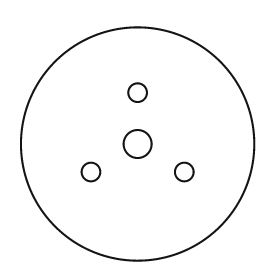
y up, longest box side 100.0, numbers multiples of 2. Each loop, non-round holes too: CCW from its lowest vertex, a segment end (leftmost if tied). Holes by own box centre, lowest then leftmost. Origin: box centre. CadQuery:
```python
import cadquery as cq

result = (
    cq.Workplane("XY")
    .moveTo(0.0, 0.0)
    .circle(50.0)
    .moveTo(-20.0, -12.0)
    .circle(4.0)
    .moveTo(20.0, -12.0)
    .circle(4.0)
    .moveTo(0.0, 0.0)
    .circle(6.0)
    .moveTo(0.0, 22.0)
    .circle(4.0)
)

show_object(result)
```